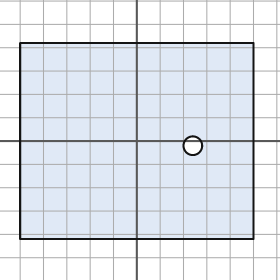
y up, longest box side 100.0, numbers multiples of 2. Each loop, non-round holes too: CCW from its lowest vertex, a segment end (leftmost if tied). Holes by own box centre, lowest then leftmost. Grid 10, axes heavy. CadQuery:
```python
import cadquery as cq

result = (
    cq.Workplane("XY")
    .moveTo(-50.0, -42.0)
    .lineTo(50.0, -42.0)
    .lineTo(50.0, 42.0)
    .lineTo(-50.0, 42.0)
    .close()
    .moveTo(24.0, -2.0)
    .circle(4.0)
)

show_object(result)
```